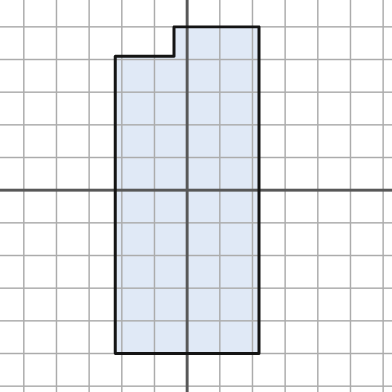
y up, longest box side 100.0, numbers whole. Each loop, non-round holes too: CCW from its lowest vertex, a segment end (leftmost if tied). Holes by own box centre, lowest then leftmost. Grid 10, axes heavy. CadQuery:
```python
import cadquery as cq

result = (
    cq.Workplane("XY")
    .moveTo(-22.0, -50.0)
    .lineTo(22.0, -50.0)
    .lineTo(22.0, 50.0)
    .lineTo(-4.0, 50.0)
    .lineTo(-4.0, 41.0)
    .lineTo(-22.0, 41.0)
    .close()
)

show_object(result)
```